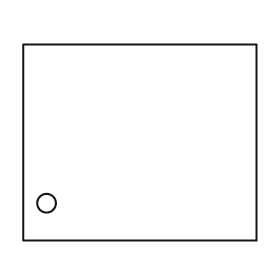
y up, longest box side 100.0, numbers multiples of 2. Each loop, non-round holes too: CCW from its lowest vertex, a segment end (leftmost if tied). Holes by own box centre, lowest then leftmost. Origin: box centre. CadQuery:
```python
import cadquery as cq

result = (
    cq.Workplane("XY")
    .moveTo(-50.0, -42.0)
    .lineTo(50.0, -42.0)
    .lineTo(50.0, 42.0)
    .lineTo(-50.0, 42.0)
    .close()
    .moveTo(-40.0, -26.0)
    .circle(4.0)
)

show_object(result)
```